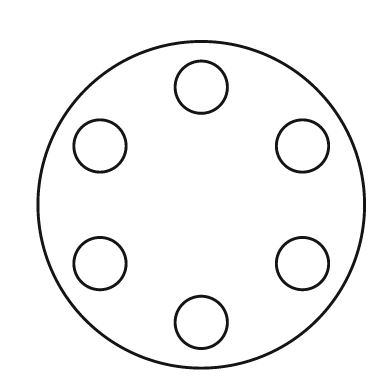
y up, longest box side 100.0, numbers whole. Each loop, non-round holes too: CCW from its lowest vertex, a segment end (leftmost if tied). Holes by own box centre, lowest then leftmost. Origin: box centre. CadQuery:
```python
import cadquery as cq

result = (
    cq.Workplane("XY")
    .moveTo(0.0, 0.0)
    .circle(50.0)
    .moveTo(0.0, -36.0)
    .circle(8.0)
    .moveTo(-31.0, -18.0)
    .circle(8.0)
    .moveTo(31.0, -18.0)
    .circle(8.0)
    .moveTo(-31.0, 18.0)
    .circle(8.0)
    .moveTo(31.0, 18.0)
    .circle(8.0)
    .moveTo(0.0, 36.0)
    .circle(8.0)
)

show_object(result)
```